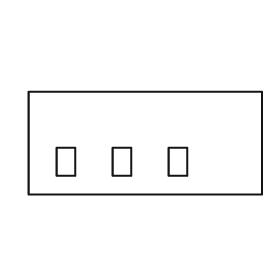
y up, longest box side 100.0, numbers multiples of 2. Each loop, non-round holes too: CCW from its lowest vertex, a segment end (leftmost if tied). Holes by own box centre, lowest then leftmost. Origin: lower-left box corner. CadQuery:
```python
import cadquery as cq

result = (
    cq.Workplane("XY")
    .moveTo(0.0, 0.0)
    .lineTo(100.0, 0.0)
    .lineTo(100.0, 44.0)
    .lineTo(0.0, 44.0)
    .close()
    .moveTo(12.0, 8.0)
    .lineTo(20.0, 8.0)
    .lineTo(20.0, 20.0)
    .lineTo(12.0, 20.0)
    .close()
    .moveTo(36.0, 8.0)
    .lineTo(44.0, 8.0)
    .lineTo(44.0, 20.0)
    .lineTo(36.0, 20.0)
    .close()
    .moveTo(60.0, 8.0)
    .lineTo(68.0, 8.0)
    .lineTo(68.0, 20.0)
    .lineTo(60.0, 20.0)
    .close()
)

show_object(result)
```